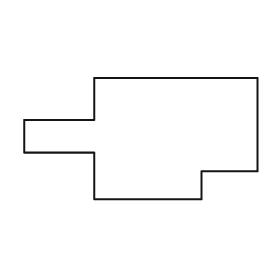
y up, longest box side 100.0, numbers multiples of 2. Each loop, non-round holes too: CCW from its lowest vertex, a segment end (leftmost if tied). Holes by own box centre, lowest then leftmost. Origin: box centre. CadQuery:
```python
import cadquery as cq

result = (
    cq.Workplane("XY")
    .moveTo(-20.0, -26.0)
    .lineTo(26.0, -26.0)
    .lineTo(26.0, -14.0)
    .lineTo(50.0, -14.0)
    .lineTo(50.0, 26.0)
    .lineTo(-20.0, 26.0)
    .lineTo(-20.0, 8.0)
    .lineTo(-50.0, 8.0)
    .lineTo(-50.0, -6.0)
    .lineTo(-20.0, -6.0)
    .close()
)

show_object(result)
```